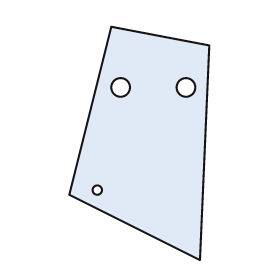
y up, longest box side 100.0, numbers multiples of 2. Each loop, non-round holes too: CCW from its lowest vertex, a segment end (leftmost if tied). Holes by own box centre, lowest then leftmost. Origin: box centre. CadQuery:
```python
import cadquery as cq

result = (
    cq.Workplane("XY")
    .moveTo(26.0, -50.0)
    .lineTo(30.0, 42.0)
    .lineTo(-12.0, 50.0)
    .lineTo(-30.0, -22.0)
    .close()
    .moveTo(-18.0, -20.0)
    .circle(2.0)
    .moveTo(-8.0, 24.0)
    .circle(4.0)
    .moveTo(20.0, 24.0)
    .circle(4.0)
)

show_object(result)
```